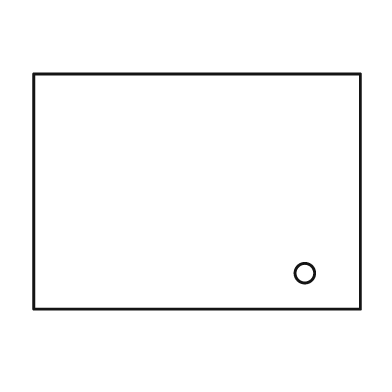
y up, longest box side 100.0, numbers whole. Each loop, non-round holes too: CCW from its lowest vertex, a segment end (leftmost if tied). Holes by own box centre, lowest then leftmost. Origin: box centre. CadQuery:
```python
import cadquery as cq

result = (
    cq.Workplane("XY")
    .moveTo(-50.0, -36.0)
    .lineTo(50.0, -36.0)
    .lineTo(50.0, 36.0)
    .lineTo(-50.0, 36.0)
    .close()
    .moveTo(33.0, -25.0)
    .circle(3.0)
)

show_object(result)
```